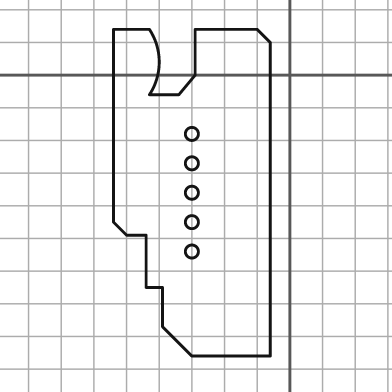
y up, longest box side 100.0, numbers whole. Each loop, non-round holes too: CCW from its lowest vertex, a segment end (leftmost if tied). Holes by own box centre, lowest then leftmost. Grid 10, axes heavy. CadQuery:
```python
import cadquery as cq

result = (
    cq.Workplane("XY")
    .moveTo(-30.0, -86.0)
    .lineTo(-6.0, -86.0)
    .lineTo(-6.0, 10.0)
    .lineTo(-10.0, 14.0)
    .lineTo(-29.0, 14.0)
    .lineTo(-29.0, 0.0)
    .lineTo(-34.0, -6.0)
    .lineTo(-43.0, -6.0)
    .threePointArc((-40.0, 4.0), (-43.0, 14.0))
    .lineTo(-54.0, 14.0)
    .lineTo(-54.0, -45.0)
    .lineTo(-50.0, -49.0)
    .lineTo(-44.0, -49.0)
    .lineTo(-44.0, -65.0)
    .lineTo(-39.0, -65.0)
    .lineTo(-39.0, -77.0)
    .close()
    .moveTo(-30.0, -54.0)
    .circle(2.0)
    .moveTo(-30.0, -45.0)
    .circle(2.0)
    .moveTo(-30.0, -36.0)
    .circle(2.0)
    .moveTo(-30.0, -27.0)
    .circle(2.0)
    .moveTo(-30.0, -18.0)
    .circle(2.0)
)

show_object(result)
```